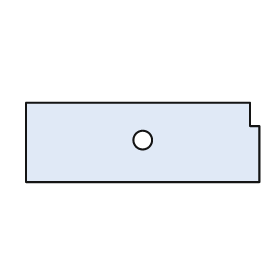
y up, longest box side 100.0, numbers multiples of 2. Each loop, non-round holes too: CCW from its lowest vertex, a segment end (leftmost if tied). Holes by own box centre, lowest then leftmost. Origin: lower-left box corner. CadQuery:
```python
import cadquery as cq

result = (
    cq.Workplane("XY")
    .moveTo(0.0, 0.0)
    .lineTo(100.0, 0.0)
    .lineTo(100.0, 24.0)
    .lineTo(96.0, 24.0)
    .lineTo(96.0, 34.0)
    .lineTo(0.0, 34.0)
    .close()
    .moveTo(50.0, 18.0)
    .circle(4.0)
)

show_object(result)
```